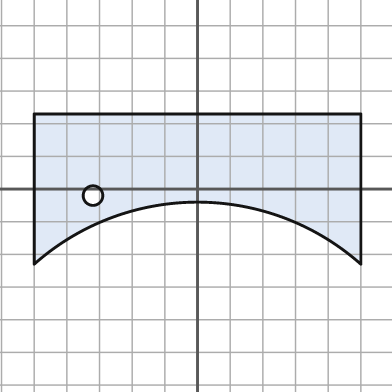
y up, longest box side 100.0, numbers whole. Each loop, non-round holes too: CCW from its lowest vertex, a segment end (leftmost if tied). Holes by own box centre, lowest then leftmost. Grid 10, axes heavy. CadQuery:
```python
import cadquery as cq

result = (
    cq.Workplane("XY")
    .moveTo(-50.0, -23.0)
    .threePointArc((0.0, -4.0), (50.0, -23.0))
    .lineTo(50.0, 23.0)
    .lineTo(-50.0, 23.0)
    .close()
    .moveTo(-32.0, -2.0)
    .circle(3.0)
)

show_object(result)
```